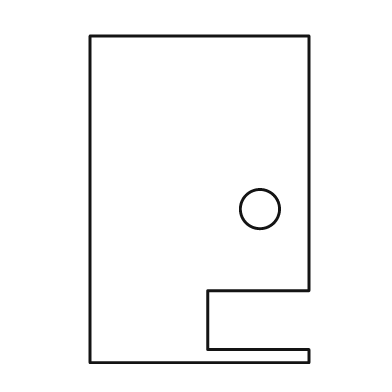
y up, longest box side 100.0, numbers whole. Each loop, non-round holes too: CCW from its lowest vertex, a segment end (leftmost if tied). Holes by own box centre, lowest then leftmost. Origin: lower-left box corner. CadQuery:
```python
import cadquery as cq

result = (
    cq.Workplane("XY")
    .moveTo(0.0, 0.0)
    .lineTo(67.0, 0.0)
    .lineTo(67.0, 4.0)
    .lineTo(36.0, 4.0)
    .lineTo(36.0, 22.0)
    .lineTo(67.0, 22.0)
    .lineTo(67.0, 100.0)
    .lineTo(0.0, 100.0)
    .close()
    .moveTo(52.0, 47.0)
    .circle(6.0)
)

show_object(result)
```